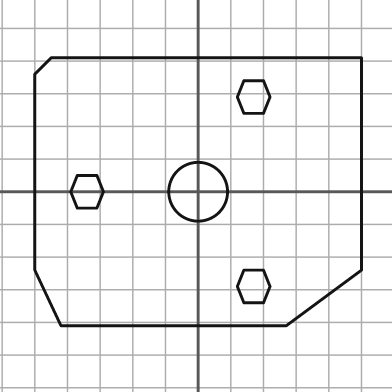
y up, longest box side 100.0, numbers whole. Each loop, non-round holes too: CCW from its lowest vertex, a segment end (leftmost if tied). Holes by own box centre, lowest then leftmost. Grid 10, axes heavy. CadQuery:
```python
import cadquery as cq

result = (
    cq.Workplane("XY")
    .moveTo(-42.0, -41.0)
    .lineTo(27.0, -41.0)
    .lineTo(50.0, -24.0)
    .lineTo(50.0, 41.0)
    .lineTo(-45.0, 41.0)
    .lineTo(-50.0, 36.0)
    .lineTo(-50.0, -24.0)
    .close()
    .moveTo(14.0, -34.0)
    .lineTo(20.0, -34.0)
    .lineTo(22.0, -29.0)
    .lineTo(20.0, -24.0)
    .lineTo(14.0, -24.0)
    .lineTo(12.0, -29.0)
    .close()
    .moveTo(-37.0, -5.0)
    .lineTo(-31.0, -5.0)
    .lineTo(-29.0, 0.0)
    .lineTo(-31.0, 5.0)
    .lineTo(-37.0, 5.0)
    .lineTo(-39.0, 0.0)
    .close()
    .moveTo(0.0, 0.0)
    .circle(9.0)
    .moveTo(14.0, 24.0)
    .lineTo(20.0, 24.0)
    .lineTo(22.0, 29.0)
    .lineTo(20.0, 34.0)
    .lineTo(14.0, 34.0)
    .lineTo(12.0, 29.0)
    .close()
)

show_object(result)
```